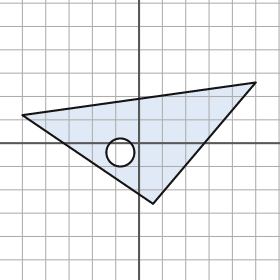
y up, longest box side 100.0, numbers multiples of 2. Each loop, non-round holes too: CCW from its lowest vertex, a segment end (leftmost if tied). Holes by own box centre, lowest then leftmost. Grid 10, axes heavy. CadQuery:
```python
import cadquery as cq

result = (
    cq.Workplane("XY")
    .moveTo(6.0, -26.0)
    .lineTo(50.0, 26.0)
    .lineTo(-50.0, 12.0)
    .close()
    .moveTo(-8.0, -4.0)
    .circle(6.0)
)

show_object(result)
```